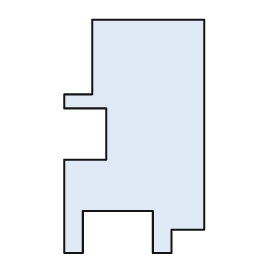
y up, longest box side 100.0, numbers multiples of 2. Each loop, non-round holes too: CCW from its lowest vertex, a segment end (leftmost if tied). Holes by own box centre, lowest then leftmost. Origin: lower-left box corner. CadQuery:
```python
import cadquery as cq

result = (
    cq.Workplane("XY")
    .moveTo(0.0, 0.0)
    .lineTo(8.0, 0.0)
    .lineTo(8.0, 18.0)
    .lineTo(38.0, 18.0)
    .lineTo(38.0, 0.0)
    .lineTo(46.0, 0.0)
    .lineTo(46.0, 10.0)
    .lineTo(60.0, 10.0)
    .lineTo(60.0, 100.0)
    .lineTo(12.0, 100.0)
    .lineTo(12.0, 68.0)
    .lineTo(0.0, 68.0)
    .lineTo(0.0, 62.0)
    .lineTo(18.0, 62.0)
    .lineTo(18.0, 40.0)
    .lineTo(0.0, 40.0)
    .close()
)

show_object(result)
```